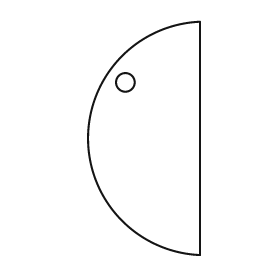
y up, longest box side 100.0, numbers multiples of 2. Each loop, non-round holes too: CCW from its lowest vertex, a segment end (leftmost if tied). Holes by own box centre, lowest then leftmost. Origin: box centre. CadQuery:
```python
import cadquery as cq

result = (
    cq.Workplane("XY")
    .moveTo(24.0, -50.0)
    .lineTo(24.0, 50.0)
    .threePointArc((-24.0, 0.0), (24.0, -50.0))
    .close()
    .moveTo(-8.0, 24.0)
    .circle(4.0)
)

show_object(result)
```